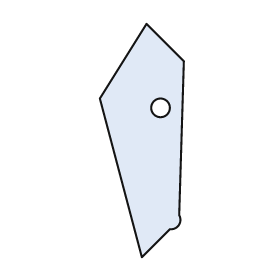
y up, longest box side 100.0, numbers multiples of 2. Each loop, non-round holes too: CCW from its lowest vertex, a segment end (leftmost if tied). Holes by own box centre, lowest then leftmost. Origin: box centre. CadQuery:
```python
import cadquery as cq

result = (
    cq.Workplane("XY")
    .moveTo(0.0, -50.0)
    .lineTo(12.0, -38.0)
    .threePointArc((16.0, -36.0), (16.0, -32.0))
    .lineTo(18.0, 34.0)
    .lineTo(2.0, 50.0)
    .lineTo(-18.0, 18.0)
    .close()
    .moveTo(8.0, 14.0)
    .circle(4.0)
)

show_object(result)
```